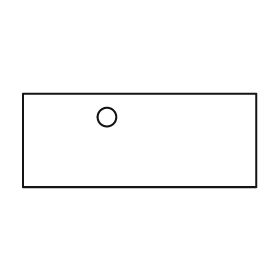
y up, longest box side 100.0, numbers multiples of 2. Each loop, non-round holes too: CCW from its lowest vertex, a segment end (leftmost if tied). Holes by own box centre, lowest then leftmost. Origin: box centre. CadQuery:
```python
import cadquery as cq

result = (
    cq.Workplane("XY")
    .moveTo(-50.0, -20.0)
    .lineTo(50.0, -20.0)
    .lineTo(50.0, 20.0)
    .lineTo(-50.0, 20.0)
    .close()
    .moveTo(-14.0, 10.0)
    .circle(4.0)
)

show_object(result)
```